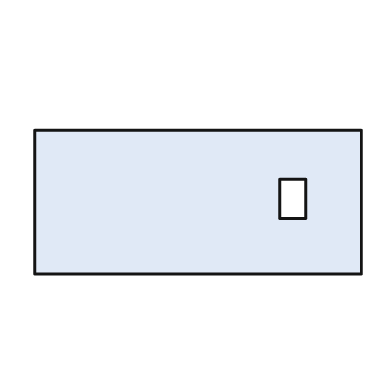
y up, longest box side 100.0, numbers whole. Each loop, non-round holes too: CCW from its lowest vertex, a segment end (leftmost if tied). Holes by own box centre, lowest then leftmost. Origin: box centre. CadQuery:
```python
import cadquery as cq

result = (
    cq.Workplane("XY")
    .moveTo(-50.0, -22.0)
    .lineTo(50.0, -22.0)
    .lineTo(50.0, 22.0)
    .lineTo(-50.0, 22.0)
    .close()
    .moveTo(25.0, -5.0)
    .lineTo(33.0, -5.0)
    .lineTo(33.0, 7.0)
    .lineTo(25.0, 7.0)
    .close()
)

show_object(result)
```